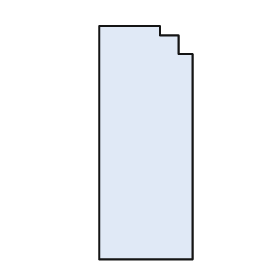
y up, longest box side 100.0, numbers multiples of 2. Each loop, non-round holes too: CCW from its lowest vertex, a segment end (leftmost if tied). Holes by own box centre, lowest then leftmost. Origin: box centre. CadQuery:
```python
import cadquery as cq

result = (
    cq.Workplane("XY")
    .moveTo(-20.0, -50.0)
    .lineTo(20.0, -50.0)
    .lineTo(20.0, 38.0)
    .lineTo(14.0, 38.0)
    .lineTo(14.0, 46.0)
    .lineTo(6.0, 46.0)
    .lineTo(6.0, 50.0)
    .lineTo(-20.0, 50.0)
    .close()
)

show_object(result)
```